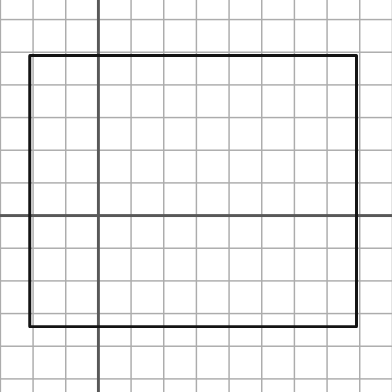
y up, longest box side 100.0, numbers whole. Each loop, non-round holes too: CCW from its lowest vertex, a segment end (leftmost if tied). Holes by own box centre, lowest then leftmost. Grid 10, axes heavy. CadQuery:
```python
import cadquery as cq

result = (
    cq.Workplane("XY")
    .moveTo(-21.0, -34.0)
    .lineTo(79.0, -34.0)
    .lineTo(79.0, 49.0)
    .lineTo(-21.0, 49.0)
    .close()
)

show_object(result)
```